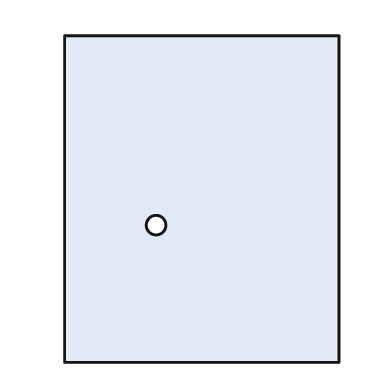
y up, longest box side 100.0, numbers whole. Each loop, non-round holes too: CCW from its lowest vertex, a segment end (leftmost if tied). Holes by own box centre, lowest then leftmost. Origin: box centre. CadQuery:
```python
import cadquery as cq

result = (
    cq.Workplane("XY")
    .moveTo(-42.0, -50.0)
    .lineTo(42.0, -50.0)
    .lineTo(42.0, 50.0)
    .lineTo(-42.0, 50.0)
    .close()
    .moveTo(-14.0, -8.0)
    .circle(3.0)
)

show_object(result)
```